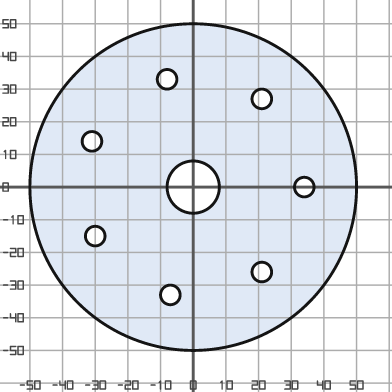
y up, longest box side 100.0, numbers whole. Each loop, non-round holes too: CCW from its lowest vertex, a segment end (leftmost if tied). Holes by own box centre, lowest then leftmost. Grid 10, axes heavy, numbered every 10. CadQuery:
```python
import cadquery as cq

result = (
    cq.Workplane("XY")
    .moveTo(0.0, 0.0)
    .circle(50.0)
    .moveTo(-7.0, -33.0)
    .circle(3.0)
    .moveTo(21.0, -26.0)
    .circle(3.0)
    .moveTo(-30.0, -15.0)
    .circle(3.0)
    .moveTo(0.0, 0.0)
    .circle(8.0)
    .moveTo(34.0, 0.0)
    .circle(3.0)
    .moveTo(-31.0, 14.0)
    .circle(3.0)
    .moveTo(21.0, 27.0)
    .circle(3.0)
    .moveTo(-8.0, 33.0)
    .circle(3.0)
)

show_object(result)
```